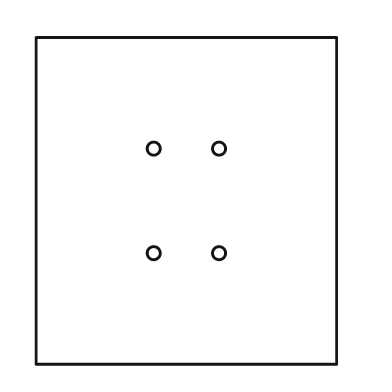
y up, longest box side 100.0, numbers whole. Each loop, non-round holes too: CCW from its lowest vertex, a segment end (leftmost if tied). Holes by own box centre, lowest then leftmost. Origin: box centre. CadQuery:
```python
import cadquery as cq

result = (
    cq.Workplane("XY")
    .moveTo(-46.0, -50.0)
    .lineTo(46.0, -50.0)
    .lineTo(46.0, 50.0)
    .lineTo(-46.0, 50.0)
    .close()
    .moveTo(-10.0, -16.0)
    .circle(2.0)
    .moveTo(10.0, -16.0)
    .circle(2.0)
    .moveTo(-10.0, 16.0)
    .circle(2.0)
    .moveTo(10.0, 16.0)
    .circle(2.0)
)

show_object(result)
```